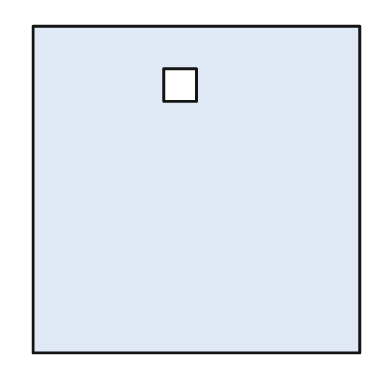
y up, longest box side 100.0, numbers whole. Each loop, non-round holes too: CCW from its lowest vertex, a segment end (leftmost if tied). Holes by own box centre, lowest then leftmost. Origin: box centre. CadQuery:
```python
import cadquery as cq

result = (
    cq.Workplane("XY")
    .moveTo(-50.0, -50.0)
    .lineTo(50.0, -50.0)
    .lineTo(50.0, 50.0)
    .lineTo(-50.0, 50.0)
    .close()
    .moveTo(-10.0, 27.0)
    .lineTo(0.0, 27.0)
    .lineTo(0.0, 37.0)
    .lineTo(-10.0, 37.0)
    .close()
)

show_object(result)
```